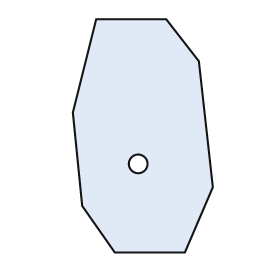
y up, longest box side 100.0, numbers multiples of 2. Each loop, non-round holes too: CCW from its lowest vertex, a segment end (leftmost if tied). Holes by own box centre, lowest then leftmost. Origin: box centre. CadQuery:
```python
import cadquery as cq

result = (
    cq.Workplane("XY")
    .moveTo(-12.0, -50.0)
    .lineTo(18.0, -50.0)
    .lineTo(30.0, -22.0)
    .lineTo(24.0, 32.0)
    .lineTo(10.0, 50.0)
    .lineTo(-20.0, 50.0)
    .lineTo(-30.0, 10.0)
    .lineTo(-26.0, -30.0)
    .close()
    .moveTo(-2.0, -12.0)
    .circle(4.0)
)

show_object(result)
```